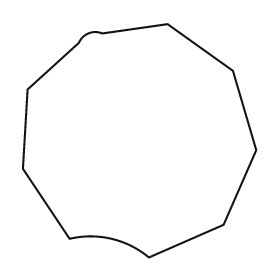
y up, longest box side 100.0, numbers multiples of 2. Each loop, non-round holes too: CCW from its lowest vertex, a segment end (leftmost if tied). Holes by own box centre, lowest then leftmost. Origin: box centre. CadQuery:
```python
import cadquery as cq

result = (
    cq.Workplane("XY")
    .moveTo(4.0, -50.0)
    .lineTo(36.0, -36.0)
    .lineTo(50.0, -4.0)
    .lineTo(40.0, 30.0)
    .lineTo(12.0, 50.0)
    .lineTo(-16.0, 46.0)
    .threePointArc((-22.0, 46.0), (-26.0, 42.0))
    .lineTo(-48.0, 22.0)
    .lineTo(-50.0, -12.0)
    .lineTo(-30.0, -42.0)
    .threePointArc((-12.0, -42.0), (4.0, -50.0))
    .close()
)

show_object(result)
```